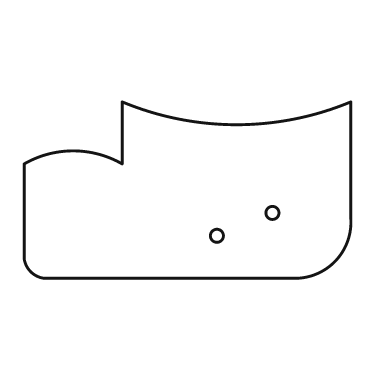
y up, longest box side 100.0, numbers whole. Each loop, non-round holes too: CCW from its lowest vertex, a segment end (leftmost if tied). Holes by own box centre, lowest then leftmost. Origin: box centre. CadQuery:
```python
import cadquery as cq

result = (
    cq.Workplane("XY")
    .moveTo(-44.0, -27.0)
    .lineTo(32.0, -27.0)
    .threePointArc((45.0, -22.0), (50.0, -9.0))
    .lineTo(50.0, 27.0)
    .threePointArc((15.0, 20.0), (-20.0, 27.0))
    .lineTo(-20.0, 8.0)
    .threePointArc((-35.0, 12.0), (-50.0, 8.0))
    .lineTo(-50.0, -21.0)
    .threePointArc((-48.0, -25.0), (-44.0, -27.0))
    .close()
    .moveTo(9.0, -14.0)
    .circle(2.0)
    .moveTo(26.0, -7.0)
    .circle(2.0)
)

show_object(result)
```